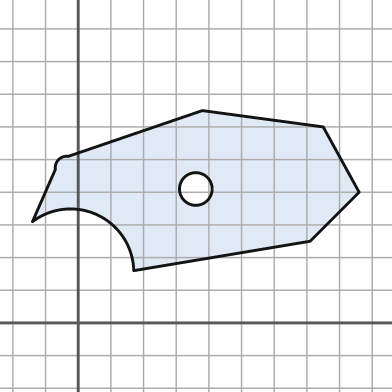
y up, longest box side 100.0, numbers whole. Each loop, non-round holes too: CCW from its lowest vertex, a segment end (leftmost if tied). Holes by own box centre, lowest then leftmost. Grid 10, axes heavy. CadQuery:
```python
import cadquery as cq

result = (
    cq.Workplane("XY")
    .moveTo(17.0, 16.0)
    .lineTo(71.0, 25.0)
    .lineTo(86.0, 40.0)
    .lineTo(75.0, 60.0)
    .lineTo(38.0, 65.0)
    .lineTo(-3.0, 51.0)
    .threePointArc((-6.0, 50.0), (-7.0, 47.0))
    .lineTo(-14.0, 31.0)
    .threePointArc((6.0, 33.0), (17.0, 16.0))
    .close()
    .moveTo(36.0, 41.0)
    .circle(5.0)
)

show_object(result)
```